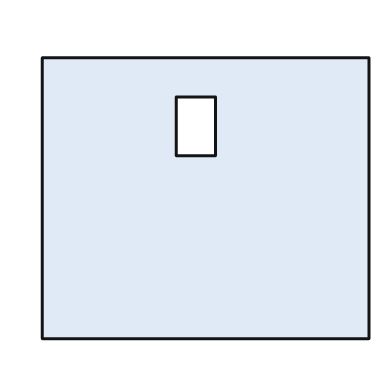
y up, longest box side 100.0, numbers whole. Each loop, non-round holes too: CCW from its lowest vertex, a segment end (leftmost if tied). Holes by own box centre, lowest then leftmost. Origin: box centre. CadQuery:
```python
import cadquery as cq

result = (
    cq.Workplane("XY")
    .moveTo(-50.0, -43.0)
    .lineTo(50.0, -43.0)
    .lineTo(50.0, 43.0)
    .lineTo(-50.0, 43.0)
    .close()
    .moveTo(-9.0, 13.0)
    .lineTo(3.0, 13.0)
    .lineTo(3.0, 31.0)
    .lineTo(-9.0, 31.0)
    .close()
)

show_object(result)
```